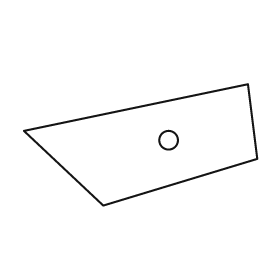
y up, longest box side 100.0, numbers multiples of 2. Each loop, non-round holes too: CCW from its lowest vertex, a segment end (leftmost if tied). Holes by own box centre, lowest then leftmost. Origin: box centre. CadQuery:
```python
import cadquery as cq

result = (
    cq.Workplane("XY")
    .moveTo(-16.0, -26.0)
    .lineTo(50.0, -6.0)
    .lineTo(46.0, 26.0)
    .lineTo(-50.0, 6.0)
    .close()
    .moveTo(12.0, 2.0)
    .circle(4.0)
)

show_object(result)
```